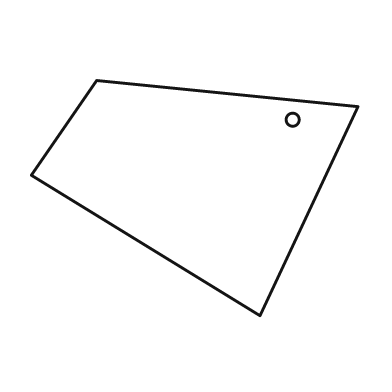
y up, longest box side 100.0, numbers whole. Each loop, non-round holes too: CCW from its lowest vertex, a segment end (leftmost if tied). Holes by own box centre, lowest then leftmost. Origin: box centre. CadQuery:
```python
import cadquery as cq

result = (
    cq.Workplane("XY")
    .moveTo(20.0, -36.0)
    .lineTo(50.0, 28.0)
    .lineTo(-30.0, 36.0)
    .lineTo(-50.0, 7.0)
    .close()
    .moveTo(30.0, 24.0)
    .circle(2.0)
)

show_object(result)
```